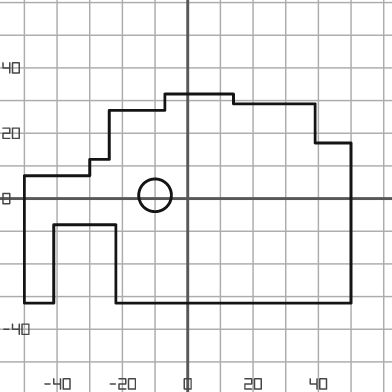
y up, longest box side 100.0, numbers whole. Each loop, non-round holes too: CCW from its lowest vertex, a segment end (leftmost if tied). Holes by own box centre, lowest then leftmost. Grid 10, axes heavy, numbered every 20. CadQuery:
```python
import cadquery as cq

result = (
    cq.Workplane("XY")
    .moveTo(-50.0, -32.0)
    .lineTo(-41.0, -32.0)
    .lineTo(-41.0, -8.0)
    .lineTo(-22.0, -8.0)
    .lineTo(-22.0, -32.0)
    .lineTo(50.0, -32.0)
    .lineTo(50.0, 17.0)
    .lineTo(39.0, 17.0)
    .lineTo(39.0, 29.0)
    .lineTo(14.0, 29.0)
    .lineTo(14.0, 32.0)
    .lineTo(-7.0, 32.0)
    .lineTo(-7.0, 27.0)
    .lineTo(-24.0, 27.0)
    .lineTo(-24.0, 12.0)
    .lineTo(-30.0, 12.0)
    .lineTo(-30.0, 7.0)
    .lineTo(-50.0, 7.0)
    .close()
    .moveTo(-10.0, 1.0)
    .circle(5.0)
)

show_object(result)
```